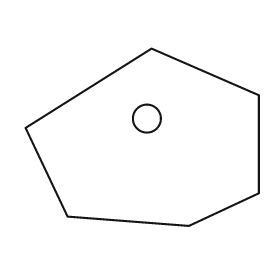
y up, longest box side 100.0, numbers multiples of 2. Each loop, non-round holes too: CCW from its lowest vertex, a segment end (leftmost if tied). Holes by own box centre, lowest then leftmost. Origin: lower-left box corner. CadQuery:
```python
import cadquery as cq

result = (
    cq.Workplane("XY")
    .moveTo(70.0, 0.0)
    .lineTo(100.0, 14.0)
    .lineTo(100.0, 56.0)
    .lineTo(54.0, 76.0)
    .lineTo(0.0, 42.0)
    .lineTo(18.0, 4.0)
    .close()
    .moveTo(52.0, 46.0)
    .circle(6.0)
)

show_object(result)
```